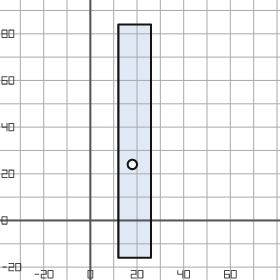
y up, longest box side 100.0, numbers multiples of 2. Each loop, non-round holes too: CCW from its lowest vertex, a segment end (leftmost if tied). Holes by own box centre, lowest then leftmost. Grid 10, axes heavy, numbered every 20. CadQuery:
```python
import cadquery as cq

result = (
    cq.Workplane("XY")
    .moveTo(12.0, -16.0)
    .lineTo(26.0, -16.0)
    .lineTo(26.0, 84.0)
    .lineTo(12.0, 84.0)
    .close()
    .moveTo(18.0, 24.0)
    .circle(2.0)
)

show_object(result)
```